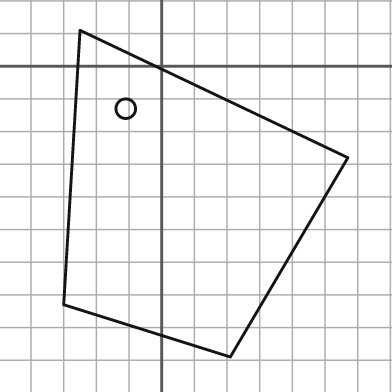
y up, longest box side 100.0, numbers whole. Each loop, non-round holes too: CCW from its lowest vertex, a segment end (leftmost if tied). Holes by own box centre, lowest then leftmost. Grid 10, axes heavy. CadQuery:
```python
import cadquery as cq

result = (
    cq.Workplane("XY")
    .moveTo(21.0, -89.0)
    .lineTo(57.0, -28.0)
    .lineTo(-25.0, 11.0)
    .lineTo(-30.0, -73.0)
    .close()
    .moveTo(-11.0, -13.0)
    .circle(3.0)
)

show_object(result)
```